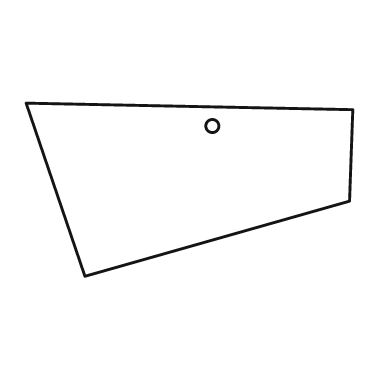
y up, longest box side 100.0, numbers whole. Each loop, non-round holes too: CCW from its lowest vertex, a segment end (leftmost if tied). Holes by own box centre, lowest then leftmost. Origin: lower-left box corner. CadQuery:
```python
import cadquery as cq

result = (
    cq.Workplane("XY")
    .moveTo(18.0, 0.0)
    .lineTo(99.0, 23.0)
    .lineTo(100.0, 51.0)
    .lineTo(0.0, 53.0)
    .close()
    .moveTo(57.0, 46.0)
    .circle(2.0)
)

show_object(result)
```